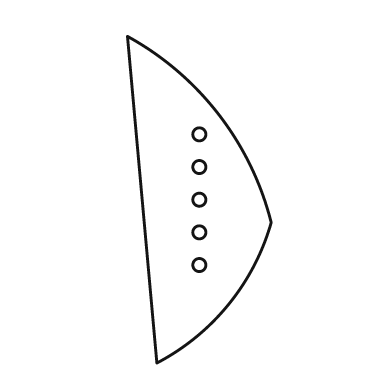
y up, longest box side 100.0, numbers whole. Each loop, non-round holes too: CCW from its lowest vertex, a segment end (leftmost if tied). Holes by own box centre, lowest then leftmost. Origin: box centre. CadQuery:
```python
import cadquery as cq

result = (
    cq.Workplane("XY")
    .moveTo(-13.0, -50.0)
    .threePointArc((9.0, -32.0), (22.0, -7.0))
    .threePointArc((6.0, 26.0), (-22.0, 50.0))
    .close()
    .moveTo(0.0, -20.0)
    .circle(2.0)
    .moveTo(0.0, -10.0)
    .circle(2.0)
    .moveTo(0.0, 0.0)
    .circle(2.0)
    .moveTo(0.0, 10.0)
    .circle(2.0)
    .moveTo(0.0, 20.0)
    .circle(2.0)
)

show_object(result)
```